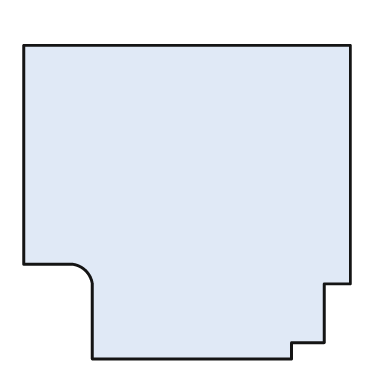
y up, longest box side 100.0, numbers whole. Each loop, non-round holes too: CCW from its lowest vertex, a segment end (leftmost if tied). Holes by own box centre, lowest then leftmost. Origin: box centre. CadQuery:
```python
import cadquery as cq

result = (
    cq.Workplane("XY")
    .moveTo(-29.0, -48.0)
    .lineTo(32.0, -48.0)
    .lineTo(32.0, -43.0)
    .lineTo(42.0, -43.0)
    .lineTo(42.0, -25.0)
    .lineTo(50.0, -25.0)
    .lineTo(50.0, 48.0)
    .lineTo(-50.0, 48.0)
    .lineTo(-50.0, -19.0)
    .lineTo(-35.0, -19.0)
    .threePointArc((-31.0, -21.0), (-29.0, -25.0))
    .close()
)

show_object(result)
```